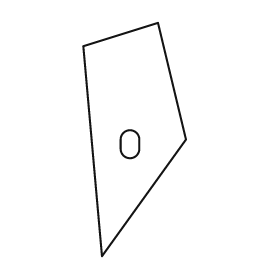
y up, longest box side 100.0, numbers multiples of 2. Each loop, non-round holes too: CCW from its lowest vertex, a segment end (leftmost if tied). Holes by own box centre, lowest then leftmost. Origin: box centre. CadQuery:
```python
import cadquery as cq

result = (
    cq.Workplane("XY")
    .moveTo(-14.0, -50.0)
    .lineTo(22.0, 0.0)
    .lineTo(10.0, 50.0)
    .lineTo(-22.0, 40.0)
    .close()
    .moveTo(-6.0, -4.0)
    .threePointArc((-2.0, -8.0), (2.0, -4.0))
    .lineTo(2.0, 0.0)
    .threePointArc((-2.0, 4.0), (-6.0, 0.0))
    .close()
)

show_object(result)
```